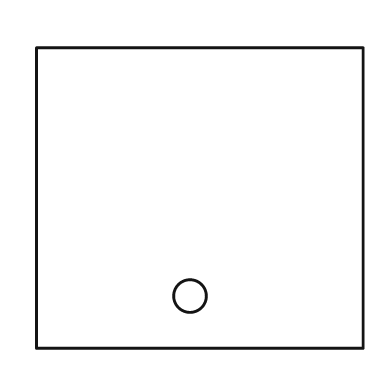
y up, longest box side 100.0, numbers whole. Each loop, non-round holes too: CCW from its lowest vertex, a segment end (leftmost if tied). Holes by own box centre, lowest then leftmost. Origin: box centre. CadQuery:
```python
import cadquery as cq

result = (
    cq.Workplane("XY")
    .moveTo(-50.0, -46.0)
    .lineTo(50.0, -46.0)
    .lineTo(50.0, 46.0)
    .lineTo(-50.0, 46.0)
    .close()
    .moveTo(-3.0, -30.0)
    .circle(5.0)
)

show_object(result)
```